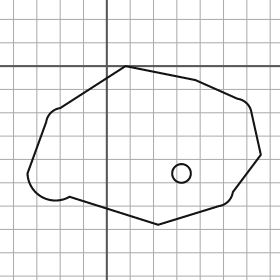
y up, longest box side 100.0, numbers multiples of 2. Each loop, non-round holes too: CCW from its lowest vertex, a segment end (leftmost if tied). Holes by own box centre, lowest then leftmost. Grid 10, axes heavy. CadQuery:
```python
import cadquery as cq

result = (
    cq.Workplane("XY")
    .moveTo(22.0, -68.0)
    .lineTo(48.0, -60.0)
    .threePointArc((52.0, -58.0), (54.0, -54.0))
    .lineTo(66.0, -38.0)
    .lineTo(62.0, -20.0)
    .threePointArc((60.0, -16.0), (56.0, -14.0))
    .lineTo(38.0, -6.0)
    .lineTo(8.0, 0.0)
    .lineTo(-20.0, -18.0)
    .threePointArc((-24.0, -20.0), (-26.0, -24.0))
    .lineTo(-34.0, -46.0)
    .threePointArc((-28.0, -56.0), (-16.0, -56.0))
    .close()
    .moveTo(32.0, -46.0)
    .circle(4.0)
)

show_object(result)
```